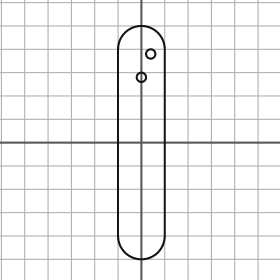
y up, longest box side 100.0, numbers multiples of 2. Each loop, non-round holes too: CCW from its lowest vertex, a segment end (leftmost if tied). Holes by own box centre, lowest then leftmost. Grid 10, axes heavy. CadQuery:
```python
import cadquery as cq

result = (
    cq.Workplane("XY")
    .moveTo(-10.0, -40.0)
    .threePointArc((0.0, -50.0), (10.0, -40.0))
    .lineTo(10.0, 40.0)
    .threePointArc((0.0, 50.0), (-10.0, 40.0))
    .close()
    .moveTo(0.0, 28.0)
    .circle(2.0)
    .moveTo(4.0, 38.0)
    .circle(2.0)
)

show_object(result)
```